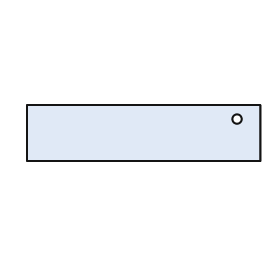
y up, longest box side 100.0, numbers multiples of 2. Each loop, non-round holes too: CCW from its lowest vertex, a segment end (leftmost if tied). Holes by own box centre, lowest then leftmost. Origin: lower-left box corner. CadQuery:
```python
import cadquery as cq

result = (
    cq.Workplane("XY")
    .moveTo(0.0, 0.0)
    .lineTo(100.0, 0.0)
    .lineTo(100.0, 24.0)
    .lineTo(0.0, 24.0)
    .close()
    .moveTo(90.0, 18.0)
    .circle(2.0)
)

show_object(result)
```